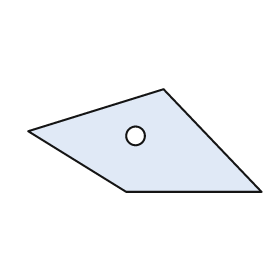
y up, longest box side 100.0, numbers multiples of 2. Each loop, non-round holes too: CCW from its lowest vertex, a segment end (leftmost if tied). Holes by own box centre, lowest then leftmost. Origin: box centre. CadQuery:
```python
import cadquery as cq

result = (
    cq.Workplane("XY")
    .moveTo(-8.0, -22.0)
    .lineTo(50.0, -22.0)
    .lineTo(8.0, 22.0)
    .lineTo(-50.0, 4.0)
    .close()
    .moveTo(-4.0, 2.0)
    .circle(4.0)
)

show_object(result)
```